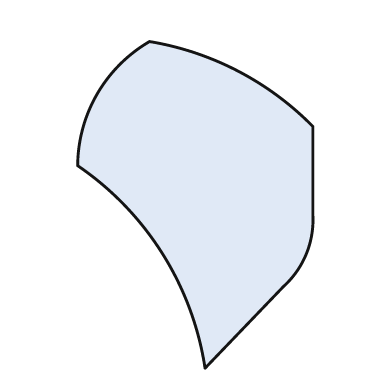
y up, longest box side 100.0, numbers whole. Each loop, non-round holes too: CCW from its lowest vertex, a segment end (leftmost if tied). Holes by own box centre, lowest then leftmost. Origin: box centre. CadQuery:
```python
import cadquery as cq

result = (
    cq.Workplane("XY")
    .moveTo(3.0, -50.0)
    .lineTo(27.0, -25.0)
    .threePointArc((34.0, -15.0), (36.0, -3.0))
    .lineTo(36.0, 24.0)
    .threePointArc((13.0, 41.0), (-14.0, 50.0))
    .threePointArc((-30.0, 34.0), (-36.0, 12.0))
    .threePointArc((-10.0, -15.0), (3.0, -50.0))
    .close()
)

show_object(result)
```